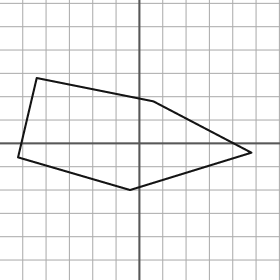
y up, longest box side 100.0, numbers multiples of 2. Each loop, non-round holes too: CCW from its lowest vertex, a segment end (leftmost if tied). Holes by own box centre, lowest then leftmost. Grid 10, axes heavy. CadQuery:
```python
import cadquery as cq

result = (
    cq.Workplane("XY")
    .moveTo(-4.0, -20.0)
    .lineTo(48.0, -4.0)
    .lineTo(6.0, 18.0)
    .lineTo(-44.0, 28.0)
    .lineTo(-52.0, -6.0)
    .close()
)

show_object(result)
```